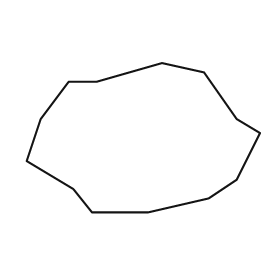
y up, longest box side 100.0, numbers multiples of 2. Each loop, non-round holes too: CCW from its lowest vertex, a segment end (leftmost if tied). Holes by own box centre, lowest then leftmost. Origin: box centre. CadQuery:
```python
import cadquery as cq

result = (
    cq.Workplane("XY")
    .moveTo(-22.0, -32.0)
    .lineTo(2.0, -32.0)
    .lineTo(28.0, -26.0)
    .lineTo(40.0, -18.0)
    .lineTo(50.0, 2.0)
    .lineTo(40.0, 8.0)
    .lineTo(26.0, 28.0)
    .lineTo(8.0, 32.0)
    .lineTo(-20.0, 24.0)
    .lineTo(-32.0, 24.0)
    .lineTo(-44.0, 8.0)
    .lineTo(-50.0, -10.0)
    .lineTo(-30.0, -22.0)
    .close()
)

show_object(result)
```